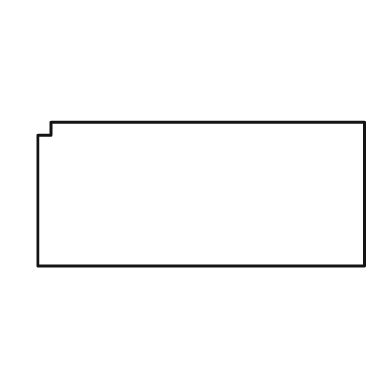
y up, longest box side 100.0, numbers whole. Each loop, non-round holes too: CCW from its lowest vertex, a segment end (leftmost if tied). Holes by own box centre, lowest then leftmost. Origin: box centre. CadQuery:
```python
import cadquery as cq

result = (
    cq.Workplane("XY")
    .moveTo(-50.0, -22.0)
    .lineTo(50.0, -22.0)
    .lineTo(50.0, 22.0)
    .lineTo(-46.0, 22.0)
    .lineTo(-46.0, 18.0)
    .lineTo(-50.0, 18.0)
    .close()
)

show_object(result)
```